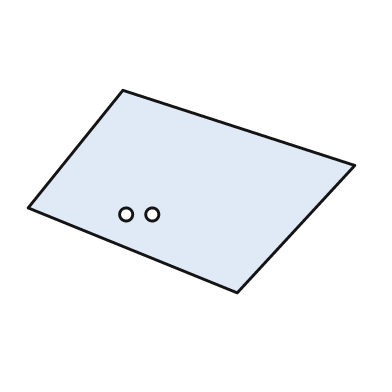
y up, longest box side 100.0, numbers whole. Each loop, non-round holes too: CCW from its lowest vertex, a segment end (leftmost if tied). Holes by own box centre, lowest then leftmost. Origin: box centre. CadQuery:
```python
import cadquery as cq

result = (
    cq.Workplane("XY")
    .moveTo(14.0, -31.0)
    .lineTo(50.0, 8.0)
    .lineTo(-21.0, 31.0)
    .lineTo(-50.0, -5.0)
    .close()
    .moveTo(-20.0, -7.0)
    .circle(2.0)
    .moveTo(-12.0, -7.0)
    .circle(2.0)
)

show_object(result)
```